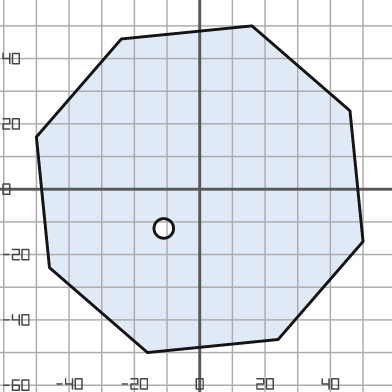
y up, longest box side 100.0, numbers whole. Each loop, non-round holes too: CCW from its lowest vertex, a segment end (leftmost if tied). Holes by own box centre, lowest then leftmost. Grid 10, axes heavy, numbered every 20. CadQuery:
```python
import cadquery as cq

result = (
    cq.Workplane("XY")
    .moveTo(-16.0, -50.0)
    .lineTo(24.0, -46.0)
    .lineTo(50.0, -16.0)
    .lineTo(46.0, 24.0)
    .lineTo(16.0, 50.0)
    .lineTo(-24.0, 46.0)
    .lineTo(-50.0, 16.0)
    .lineTo(-46.0, -24.0)
    .close()
    .moveTo(-11.0, -12.0)
    .circle(3.0)
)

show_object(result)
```